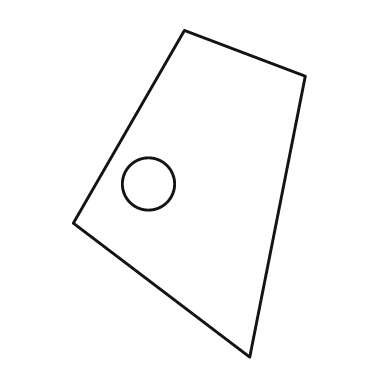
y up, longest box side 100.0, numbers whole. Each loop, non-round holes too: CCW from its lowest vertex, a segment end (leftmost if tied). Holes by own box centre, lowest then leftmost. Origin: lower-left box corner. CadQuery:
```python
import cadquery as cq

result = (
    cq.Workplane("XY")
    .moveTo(54.0, 0.0)
    .lineTo(71.0, 86.0)
    .lineTo(34.0, 100.0)
    .lineTo(0.0, 41.0)
    .close()
    .moveTo(23.0, 53.0)
    .circle(8.0)
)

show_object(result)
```